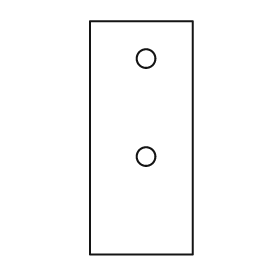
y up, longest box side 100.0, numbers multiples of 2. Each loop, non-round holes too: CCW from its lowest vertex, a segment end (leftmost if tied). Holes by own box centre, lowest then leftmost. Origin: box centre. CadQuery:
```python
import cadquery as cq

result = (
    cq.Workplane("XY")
    .moveTo(-22.0, -50.0)
    .lineTo(22.0, -50.0)
    .lineTo(22.0, 50.0)
    .lineTo(-22.0, 50.0)
    .close()
    .moveTo(2.0, -8.0)
    .circle(4.0)
    .moveTo(2.0, 34.0)
    .circle(4.0)
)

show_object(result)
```